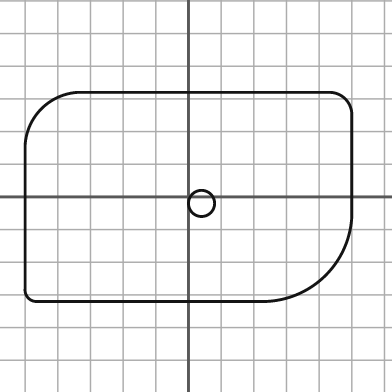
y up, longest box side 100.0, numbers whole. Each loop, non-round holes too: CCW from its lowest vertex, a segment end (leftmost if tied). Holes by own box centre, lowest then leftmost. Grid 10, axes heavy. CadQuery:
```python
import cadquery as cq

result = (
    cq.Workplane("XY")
    .moveTo(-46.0, -32.0)
    .lineTo(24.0, -32.0)
    .threePointArc((42.0, -24.0), (50.0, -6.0))
    .lineTo(50.0, 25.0)
    .threePointArc((48.0, 30.0), (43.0, 32.0))
    .lineTo(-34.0, 32.0)
    .threePointArc((-45.0, 27.0), (-50.0, 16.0))
    .lineTo(-50.0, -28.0)
    .threePointArc((-49.0, -31.0), (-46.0, -32.0))
    .close()
    .moveTo(4.0, -2.0)
    .circle(4.0)
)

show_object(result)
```